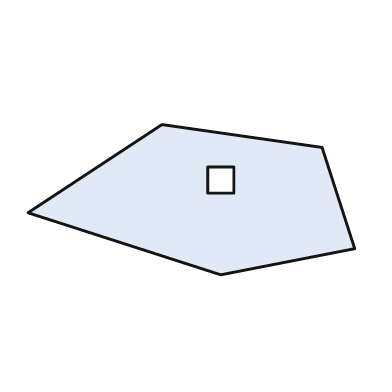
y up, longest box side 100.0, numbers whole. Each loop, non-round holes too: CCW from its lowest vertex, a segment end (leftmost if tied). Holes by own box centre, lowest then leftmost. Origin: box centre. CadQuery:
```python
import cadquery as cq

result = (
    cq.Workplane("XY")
    .moveTo(9.0, -23.0)
    .lineTo(50.0, -15.0)
    .lineTo(40.0, 16.0)
    .lineTo(-9.0, 23.0)
    .lineTo(-50.0, -4.0)
    .close()
    .moveTo(5.0, 2.0)
    .lineTo(13.0, 2.0)
    .lineTo(13.0, 10.0)
    .lineTo(5.0, 10.0)
    .close()
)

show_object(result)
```